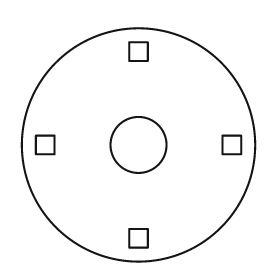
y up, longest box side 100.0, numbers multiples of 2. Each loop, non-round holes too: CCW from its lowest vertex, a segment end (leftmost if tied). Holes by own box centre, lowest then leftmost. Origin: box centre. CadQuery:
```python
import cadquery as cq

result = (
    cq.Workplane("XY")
    .moveTo(0.0, 0.0)
    .circle(50.0)
    .moveTo(-4.0, -44.0)
    .lineTo(4.0, -44.0)
    .lineTo(4.0, -36.0)
    .lineTo(-4.0, -36.0)
    .close()
    .moveTo(-44.0, -4.0)
    .lineTo(-36.0, -4.0)
    .lineTo(-36.0, 4.0)
    .lineTo(-44.0, 4.0)
    .close()
    .moveTo(0.0, 0.0)
    .circle(12.0)
    .moveTo(36.0, -4.0)
    .lineTo(44.0, -4.0)
    .lineTo(44.0, 4.0)
    .lineTo(36.0, 4.0)
    .close()
    .moveTo(-4.0, 36.0)
    .lineTo(4.0, 36.0)
    .lineTo(4.0, 44.0)
    .lineTo(-4.0, 44.0)
    .close()
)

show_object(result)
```